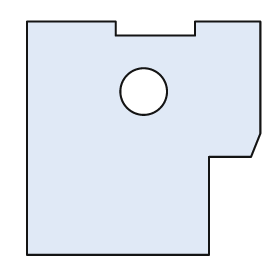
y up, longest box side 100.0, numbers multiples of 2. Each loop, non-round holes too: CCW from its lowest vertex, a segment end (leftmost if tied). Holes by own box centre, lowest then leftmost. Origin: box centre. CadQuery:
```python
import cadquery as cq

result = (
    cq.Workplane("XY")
    .moveTo(-50.0, -50.0)
    .lineTo(28.0, -50.0)
    .lineTo(28.0, -8.0)
    .lineTo(46.0, -8.0)
    .lineTo(50.0, 2.0)
    .lineTo(50.0, 50.0)
    .lineTo(22.0, 50.0)
    .lineTo(22.0, 44.0)
    .lineTo(-12.0, 44.0)
    .lineTo(-12.0, 50.0)
    .lineTo(-50.0, 50.0)
    .close()
    .moveTo(0.0, 20.0)
    .circle(10.0)
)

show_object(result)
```